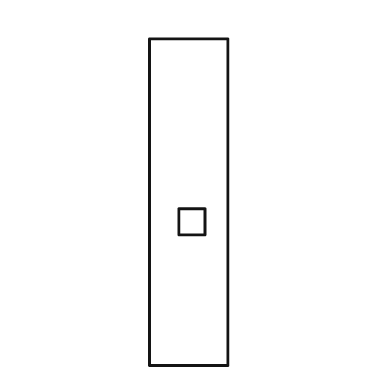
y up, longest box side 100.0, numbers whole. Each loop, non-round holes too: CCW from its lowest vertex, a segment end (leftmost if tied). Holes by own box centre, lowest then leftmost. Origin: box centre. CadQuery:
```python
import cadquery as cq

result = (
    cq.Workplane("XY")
    .moveTo(-12.0, -50.0)
    .lineTo(12.0, -50.0)
    .lineTo(12.0, 50.0)
    .lineTo(-12.0, 50.0)
    .close()
    .moveTo(-3.0, -10.0)
    .lineTo(5.0, -10.0)
    .lineTo(5.0, -2.0)
    .lineTo(-3.0, -2.0)
    .close()
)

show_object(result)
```